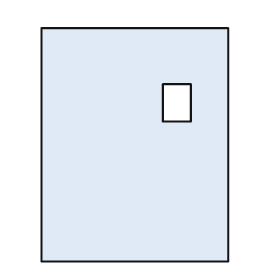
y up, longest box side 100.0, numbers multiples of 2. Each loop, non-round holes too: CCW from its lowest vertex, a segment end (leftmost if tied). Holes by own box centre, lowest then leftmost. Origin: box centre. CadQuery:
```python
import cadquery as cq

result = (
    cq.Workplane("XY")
    .moveTo(-40.0, -50.0)
    .lineTo(40.0, -50.0)
    .lineTo(40.0, 50.0)
    .lineTo(-40.0, 50.0)
    .close()
    .moveTo(12.0, 10.0)
    .lineTo(24.0, 10.0)
    .lineTo(24.0, 26.0)
    .lineTo(12.0, 26.0)
    .close()
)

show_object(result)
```